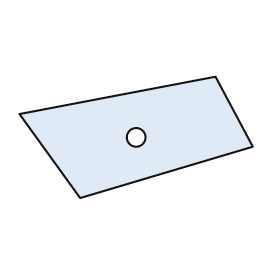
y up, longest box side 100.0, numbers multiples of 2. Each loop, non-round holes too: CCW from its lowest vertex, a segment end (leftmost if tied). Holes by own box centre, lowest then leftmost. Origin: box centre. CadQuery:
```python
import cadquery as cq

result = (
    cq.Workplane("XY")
    .moveTo(-24.0, -26.0)
    .lineTo(50.0, -4.0)
    .lineTo(34.0, 26.0)
    .lineTo(-50.0, 10.0)
    .close()
    .moveTo(0.0, 0.0)
    .circle(4.0)
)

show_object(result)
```